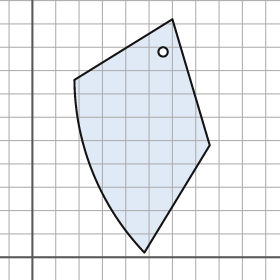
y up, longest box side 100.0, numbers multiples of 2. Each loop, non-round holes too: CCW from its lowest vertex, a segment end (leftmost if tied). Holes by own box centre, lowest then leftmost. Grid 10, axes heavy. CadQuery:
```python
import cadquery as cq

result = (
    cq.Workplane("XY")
    .moveTo(48.0, 2.0)
    .lineTo(76.0, 48.0)
    .lineTo(60.0, 102.0)
    .lineTo(18.0, 76.0)
    .threePointArc((26.0, 36.0), (48.0, 2.0))
    .close()
    .moveTo(56.0, 88.0)
    .circle(2.0)
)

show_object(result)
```